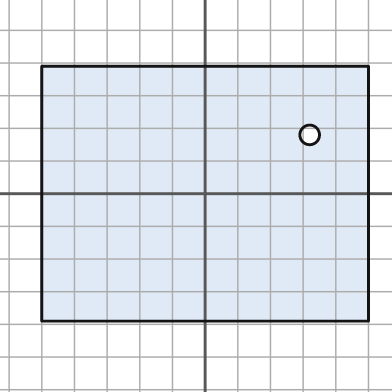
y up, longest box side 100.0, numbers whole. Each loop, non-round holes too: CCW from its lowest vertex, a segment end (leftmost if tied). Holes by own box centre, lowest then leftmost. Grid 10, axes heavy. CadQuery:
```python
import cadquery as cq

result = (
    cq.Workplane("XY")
    .moveTo(-50.0, -39.0)
    .lineTo(50.0, -39.0)
    .lineTo(50.0, 39.0)
    .lineTo(-50.0, 39.0)
    .close()
    .moveTo(32.0, 18.0)
    .circle(3.0)
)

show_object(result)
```